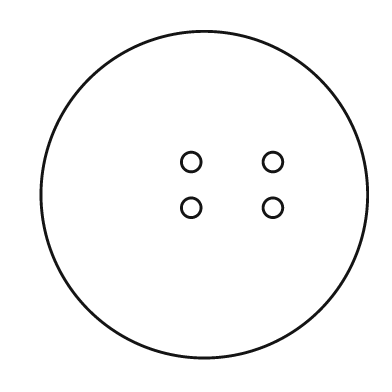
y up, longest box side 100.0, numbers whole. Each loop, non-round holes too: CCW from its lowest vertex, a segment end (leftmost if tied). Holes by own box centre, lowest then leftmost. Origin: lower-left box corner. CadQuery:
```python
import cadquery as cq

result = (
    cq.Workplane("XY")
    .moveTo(50.0, 50.0)
    .circle(50.0)
    .moveTo(46.0, 46.0)
    .circle(3.0)
    .moveTo(71.0, 46.0)
    .circle(3.0)
    .moveTo(46.0, 60.0)
    .circle(3.0)
    .moveTo(71.0, 60.0)
    .circle(3.0)
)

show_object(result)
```